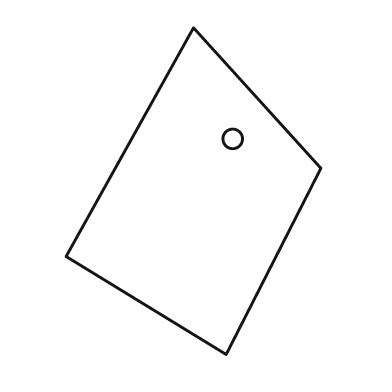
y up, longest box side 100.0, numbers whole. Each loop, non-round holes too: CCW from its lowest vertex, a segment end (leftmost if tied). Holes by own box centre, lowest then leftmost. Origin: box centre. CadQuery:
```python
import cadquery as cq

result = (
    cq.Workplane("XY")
    .moveTo(10.0, -50.0)
    .lineTo(39.0, 7.0)
    .lineTo(0.0, 50.0)
    .lineTo(-39.0, -20.0)
    .close()
    .moveTo(12.0, 16.0)
    .circle(3.0)
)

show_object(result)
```